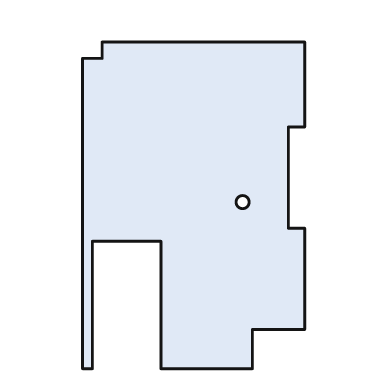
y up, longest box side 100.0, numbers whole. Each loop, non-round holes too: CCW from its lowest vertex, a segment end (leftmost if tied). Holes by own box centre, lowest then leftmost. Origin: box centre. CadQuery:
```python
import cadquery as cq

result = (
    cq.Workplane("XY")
    .moveTo(-34.0, -50.0)
    .lineTo(-31.0, -50.0)
    .lineTo(-31.0, -11.0)
    .lineTo(-10.0, -11.0)
    .lineTo(-10.0, -50.0)
    .lineTo(18.0, -50.0)
    .lineTo(18.0, -38.0)
    .lineTo(34.0, -38.0)
    .lineTo(34.0, -7.0)
    .lineTo(29.0, -7.0)
    .lineTo(29.0, 24.0)
    .lineTo(34.0, 24.0)
    .lineTo(34.0, 50.0)
    .lineTo(-28.0, 50.0)
    .lineTo(-28.0, 45.0)
    .lineTo(-34.0, 45.0)
    .close()
    .moveTo(15.0, 1.0)
    .circle(2.0)
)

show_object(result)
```